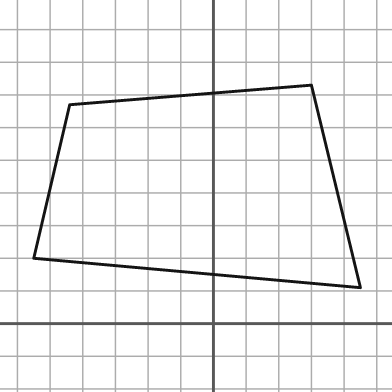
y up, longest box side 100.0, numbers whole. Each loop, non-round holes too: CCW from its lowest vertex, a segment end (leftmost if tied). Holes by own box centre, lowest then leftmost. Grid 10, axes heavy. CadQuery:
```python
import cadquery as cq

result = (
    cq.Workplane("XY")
    .moveTo(45.0, 11.0)
    .lineTo(30.0, 73.0)
    .lineTo(-44.0, 67.0)
    .lineTo(-55.0, 20.0)
    .close()
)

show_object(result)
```